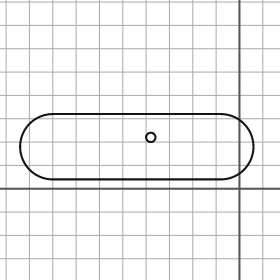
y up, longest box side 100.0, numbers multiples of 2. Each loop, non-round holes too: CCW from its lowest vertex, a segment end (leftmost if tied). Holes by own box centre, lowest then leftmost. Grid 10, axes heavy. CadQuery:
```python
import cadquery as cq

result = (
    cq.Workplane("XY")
    .moveTo(-80.0, 4.0)
    .lineTo(-8.0, 4.0)
    .threePointArc((6.0, 18.0), (-8.0, 32.0))
    .lineTo(-80.0, 32.0)
    .threePointArc((-94.0, 18.0), (-80.0, 4.0))
    .close()
    .moveTo(-38.0, 22.0)
    .circle(2.0)
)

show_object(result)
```